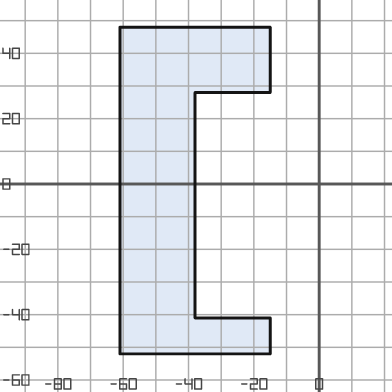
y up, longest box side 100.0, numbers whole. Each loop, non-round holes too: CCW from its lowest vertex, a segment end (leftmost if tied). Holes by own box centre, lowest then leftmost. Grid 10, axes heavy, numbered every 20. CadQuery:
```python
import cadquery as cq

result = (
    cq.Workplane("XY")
    .moveTo(-61.0, -52.0)
    .lineTo(-15.0, -52.0)
    .lineTo(-15.0, -41.0)
    .lineTo(-38.0, -41.0)
    .lineTo(-38.0, 28.0)
    .lineTo(-15.0, 28.0)
    .lineTo(-15.0, 48.0)
    .lineTo(-61.0, 48.0)
    .close()
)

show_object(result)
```